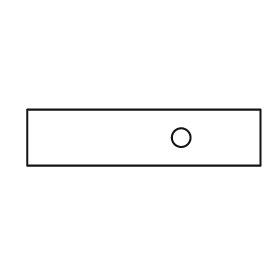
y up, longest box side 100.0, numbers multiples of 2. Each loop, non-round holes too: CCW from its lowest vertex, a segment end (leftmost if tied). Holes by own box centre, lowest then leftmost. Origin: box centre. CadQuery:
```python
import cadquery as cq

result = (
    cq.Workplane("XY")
    .moveTo(-50.0, -12.0)
    .lineTo(50.0, -12.0)
    .lineTo(50.0, 12.0)
    .lineTo(-50.0, 12.0)
    .close()
    .moveTo(16.0, 0.0)
    .circle(4.0)
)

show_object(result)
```